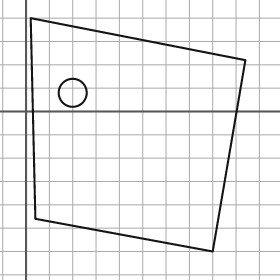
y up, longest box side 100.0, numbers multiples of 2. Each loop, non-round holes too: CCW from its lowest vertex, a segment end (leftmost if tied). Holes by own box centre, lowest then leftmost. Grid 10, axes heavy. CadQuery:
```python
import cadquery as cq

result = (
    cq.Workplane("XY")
    .moveTo(80.0, -60.0)
    .lineTo(94.0, 22.0)
    .lineTo(2.0, 40.0)
    .lineTo(4.0, -46.0)
    .close()
    .moveTo(20.0, 8.0)
    .circle(6.0)
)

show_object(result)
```